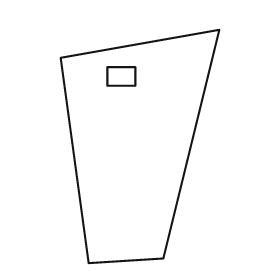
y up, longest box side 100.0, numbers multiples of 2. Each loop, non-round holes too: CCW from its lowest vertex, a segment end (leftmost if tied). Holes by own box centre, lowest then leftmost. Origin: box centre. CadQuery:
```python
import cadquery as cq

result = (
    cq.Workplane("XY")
    .moveTo(-22.0, -50.0)
    .lineTo(10.0, -48.0)
    .lineTo(34.0, 50.0)
    .lineTo(-34.0, 38.0)
    .close()
    .moveTo(-14.0, 26.0)
    .lineTo(-2.0, 26.0)
    .lineTo(-2.0, 34.0)
    .lineTo(-14.0, 34.0)
    .close()
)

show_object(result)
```